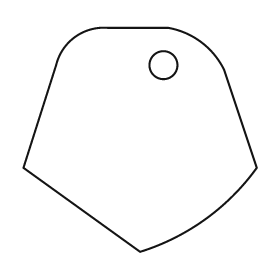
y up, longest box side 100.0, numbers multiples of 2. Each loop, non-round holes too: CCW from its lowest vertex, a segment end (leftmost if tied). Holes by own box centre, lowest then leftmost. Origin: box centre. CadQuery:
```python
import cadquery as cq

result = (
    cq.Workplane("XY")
    .moveTo(0.0, -48.0)
    .threePointArc((28.0, -34.0), (50.0, -12.0))
    .lineTo(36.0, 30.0)
    .threePointArc((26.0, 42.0), (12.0, 48.0))
    .lineTo(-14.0, 48.0)
    .threePointArc((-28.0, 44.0), (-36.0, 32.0))
    .lineTo(-50.0, -12.0)
    .close()
    .moveTo(10.0, 32.0)
    .circle(6.0)
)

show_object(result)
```